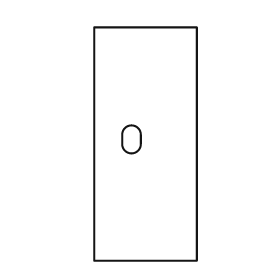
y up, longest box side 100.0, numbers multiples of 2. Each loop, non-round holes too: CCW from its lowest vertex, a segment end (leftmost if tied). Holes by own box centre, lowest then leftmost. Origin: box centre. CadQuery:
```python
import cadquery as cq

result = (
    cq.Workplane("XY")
    .moveTo(-22.0, -50.0)
    .lineTo(22.0, -50.0)
    .lineTo(22.0, 50.0)
    .lineTo(-22.0, 50.0)
    .close()
    .moveTo(-10.0, 0.0)
    .threePointArc((-6.0, -4.0), (-2.0, 0.0))
    .lineTo(-2.0, 4.0)
    .threePointArc((-6.0, 8.0), (-10.0, 4.0))
    .close()
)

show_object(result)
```